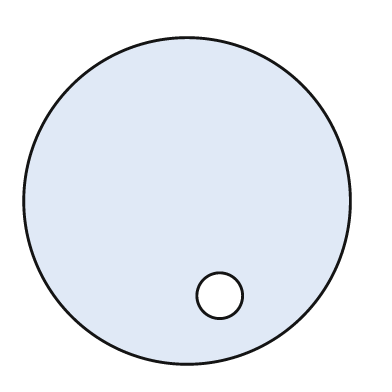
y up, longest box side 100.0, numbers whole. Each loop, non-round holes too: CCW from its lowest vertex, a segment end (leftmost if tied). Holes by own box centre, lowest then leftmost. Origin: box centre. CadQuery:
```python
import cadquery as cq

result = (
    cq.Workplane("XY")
    .moveTo(0.0, 0.0)
    .circle(50.0)
    .moveTo(10.0, -29.0)
    .circle(7.0)
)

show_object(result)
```